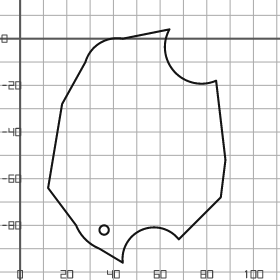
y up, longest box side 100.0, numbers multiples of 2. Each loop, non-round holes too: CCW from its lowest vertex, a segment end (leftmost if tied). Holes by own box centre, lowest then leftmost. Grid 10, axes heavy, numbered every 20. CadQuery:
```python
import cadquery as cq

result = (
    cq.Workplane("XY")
    .moveTo(44.0, -96.0)
    .threePointArc((52.0, -82.0), (68.0, -86.0))
    .lineTo(86.0, -68.0)
    .lineTo(88.0, -52.0)
    .lineTo(84.0, -18.0)
    .threePointArc((66.0, -14.0), (64.0, 4.0))
    .lineTo(44.0, 0.0)
    .threePointArc((34.0, -2.0), (28.0, -10.0))
    .lineTo(18.0, -28.0)
    .lineTo(12.0, -64.0)
    .lineTo(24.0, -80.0)
    .threePointArc((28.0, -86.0), (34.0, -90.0))
    .close()
    .moveTo(36.0, -82.0)
    .circle(2.0)
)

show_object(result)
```